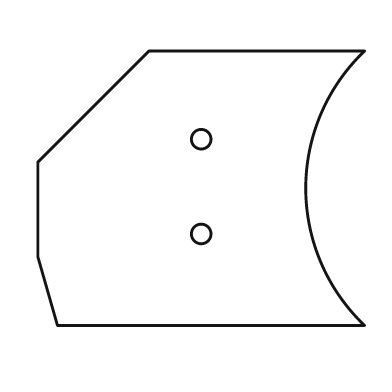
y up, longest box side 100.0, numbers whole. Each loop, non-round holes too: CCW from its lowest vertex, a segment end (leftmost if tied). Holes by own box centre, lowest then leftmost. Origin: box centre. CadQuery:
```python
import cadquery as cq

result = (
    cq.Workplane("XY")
    .moveTo(-44.0, -42.0)
    .lineTo(50.0, -42.0)
    .threePointArc((32.0, 0.0), (50.0, 42.0))
    .lineTo(-16.0, 42.0)
    .lineTo(-50.0, 8.0)
    .lineTo(-50.0, -21.0)
    .close()
    .moveTo(0.0, -14.0)
    .circle(3.0)
    .moveTo(0.0, 15.0)
    .circle(3.0)
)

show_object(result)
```